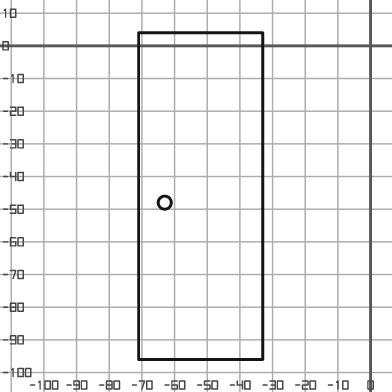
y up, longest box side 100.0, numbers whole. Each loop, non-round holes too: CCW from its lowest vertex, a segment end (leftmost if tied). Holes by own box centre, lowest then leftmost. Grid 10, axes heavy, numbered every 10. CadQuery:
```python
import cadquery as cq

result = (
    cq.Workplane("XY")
    .moveTo(-71.0, -96.0)
    .lineTo(-33.0, -96.0)
    .lineTo(-33.0, 4.0)
    .lineTo(-71.0, 4.0)
    .close()
    .moveTo(-63.0, -48.0)
    .circle(2.0)
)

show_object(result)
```